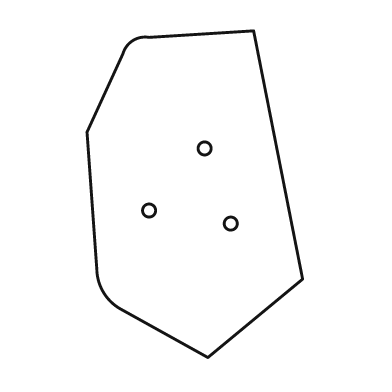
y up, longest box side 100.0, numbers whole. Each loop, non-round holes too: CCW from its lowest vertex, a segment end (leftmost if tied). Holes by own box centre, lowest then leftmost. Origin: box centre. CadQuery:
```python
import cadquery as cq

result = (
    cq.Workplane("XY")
    .moveTo(4.0, -50.0)
    .lineTo(33.0, -26.0)
    .lineTo(18.0, 50.0)
    .lineTo(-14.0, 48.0)
    .threePointArc((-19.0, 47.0), (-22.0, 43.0))
    .lineTo(-33.0, 19.0)
    .lineTo(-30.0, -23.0)
    .threePointArc((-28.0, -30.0), (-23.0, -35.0))
    .close()
    .moveTo(11.0, -9.0)
    .circle(2.0)
    .moveTo(-14.0, -5.0)
    .circle(2.0)
    .moveTo(3.0, 14.0)
    .circle(2.0)
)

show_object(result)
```